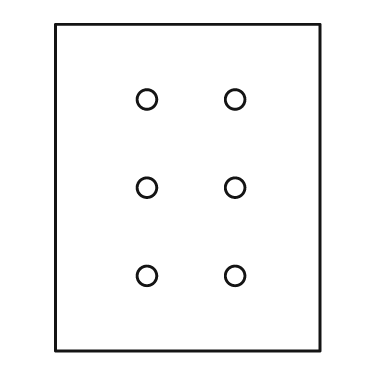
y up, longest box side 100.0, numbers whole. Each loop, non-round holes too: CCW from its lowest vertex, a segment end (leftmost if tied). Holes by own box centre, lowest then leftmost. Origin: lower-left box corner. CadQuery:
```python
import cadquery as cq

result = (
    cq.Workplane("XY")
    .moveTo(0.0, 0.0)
    .lineTo(81.0, 0.0)
    .lineTo(81.0, 100.0)
    .lineTo(0.0, 100.0)
    .close()
    .moveTo(28.0, 23.0)
    .circle(3.0)
    .moveTo(55.0, 23.0)
    .circle(3.0)
    .moveTo(28.0, 50.0)
    .circle(3.0)
    .moveTo(55.0, 50.0)
    .circle(3.0)
    .moveTo(28.0, 77.0)
    .circle(3.0)
    .moveTo(55.0, 77.0)
    .circle(3.0)
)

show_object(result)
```